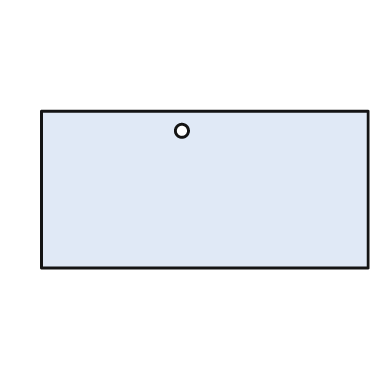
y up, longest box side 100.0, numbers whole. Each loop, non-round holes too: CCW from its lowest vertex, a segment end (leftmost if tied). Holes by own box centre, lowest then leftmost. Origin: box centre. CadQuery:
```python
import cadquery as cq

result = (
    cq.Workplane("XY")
    .moveTo(-50.0, -24.0)
    .lineTo(50.0, -24.0)
    .lineTo(50.0, 24.0)
    .lineTo(-50.0, 24.0)
    .close()
    .moveTo(-7.0, 18.0)
    .circle(2.0)
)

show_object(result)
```